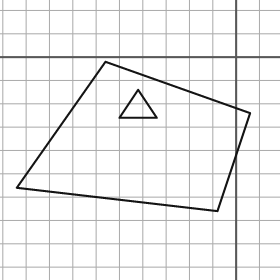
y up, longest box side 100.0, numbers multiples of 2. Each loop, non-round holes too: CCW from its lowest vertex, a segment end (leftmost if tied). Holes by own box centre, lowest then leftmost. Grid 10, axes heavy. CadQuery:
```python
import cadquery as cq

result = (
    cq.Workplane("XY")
    .moveTo(-8.0, -66.0)
    .lineTo(6.0, -24.0)
    .lineTo(-56.0, -2.0)
    .lineTo(-94.0, -56.0)
    .close()
    .moveTo(-50.0, -26.0)
    .lineTo(-34.0, -26.0)
    .lineTo(-42.0, -14.0)
    .close()
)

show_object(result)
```